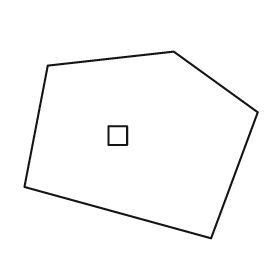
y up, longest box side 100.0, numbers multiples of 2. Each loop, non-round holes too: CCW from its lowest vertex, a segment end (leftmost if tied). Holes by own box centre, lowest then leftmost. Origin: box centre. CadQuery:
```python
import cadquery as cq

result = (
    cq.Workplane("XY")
    .moveTo(30.0, -40.0)
    .lineTo(50.0, 14.0)
    .lineTo(14.0, 40.0)
    .lineTo(-40.0, 34.0)
    .lineTo(-50.0, -18.0)
    .close()
    .moveTo(-14.0, 0.0)
    .lineTo(-6.0, 0.0)
    .lineTo(-6.0, 8.0)
    .lineTo(-14.0, 8.0)
    .close()
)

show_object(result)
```